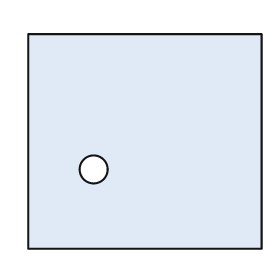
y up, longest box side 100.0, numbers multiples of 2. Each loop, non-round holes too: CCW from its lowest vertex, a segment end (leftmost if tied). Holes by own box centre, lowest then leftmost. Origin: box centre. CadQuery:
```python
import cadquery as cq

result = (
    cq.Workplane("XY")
    .moveTo(-50.0, -46.0)
    .lineTo(50.0, -46.0)
    .lineTo(50.0, 46.0)
    .lineTo(-50.0, 46.0)
    .close()
    .moveTo(-22.0, -12.0)
    .circle(6.0)
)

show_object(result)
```